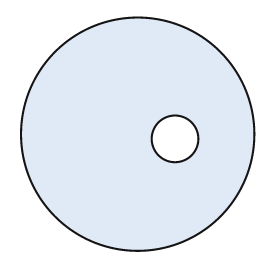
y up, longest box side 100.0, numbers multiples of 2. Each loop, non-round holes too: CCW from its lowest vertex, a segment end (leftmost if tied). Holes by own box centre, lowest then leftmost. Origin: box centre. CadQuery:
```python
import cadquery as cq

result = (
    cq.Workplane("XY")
    .moveTo(0.0, 0.0)
    .circle(50.0)
    .moveTo(16.0, -2.0)
    .circle(10.0)
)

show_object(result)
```